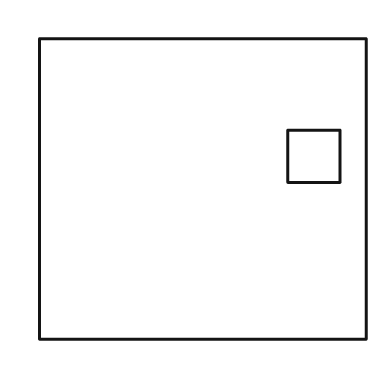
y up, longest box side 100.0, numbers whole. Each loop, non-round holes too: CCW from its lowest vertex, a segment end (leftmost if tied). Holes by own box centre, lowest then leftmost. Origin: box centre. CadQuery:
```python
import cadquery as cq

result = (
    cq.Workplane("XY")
    .moveTo(-50.0, -46.0)
    .lineTo(50.0, -46.0)
    .lineTo(50.0, 46.0)
    .lineTo(-50.0, 46.0)
    .close()
    .moveTo(26.0, 2.0)
    .lineTo(42.0, 2.0)
    .lineTo(42.0, 18.0)
    .lineTo(26.0, 18.0)
    .close()
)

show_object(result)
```